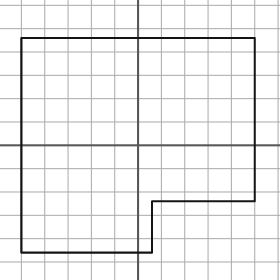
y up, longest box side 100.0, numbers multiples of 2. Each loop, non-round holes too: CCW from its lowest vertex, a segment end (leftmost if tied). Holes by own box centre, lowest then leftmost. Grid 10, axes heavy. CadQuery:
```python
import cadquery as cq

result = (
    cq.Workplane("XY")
    .moveTo(-50.0, -46.0)
    .lineTo(6.0, -46.0)
    .lineTo(6.0, -24.0)
    .lineTo(50.0, -24.0)
    .lineTo(50.0, 46.0)
    .lineTo(-50.0, 46.0)
    .close()
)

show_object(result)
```